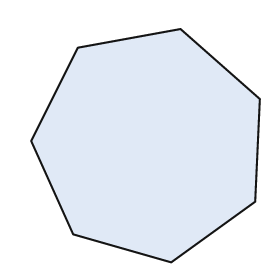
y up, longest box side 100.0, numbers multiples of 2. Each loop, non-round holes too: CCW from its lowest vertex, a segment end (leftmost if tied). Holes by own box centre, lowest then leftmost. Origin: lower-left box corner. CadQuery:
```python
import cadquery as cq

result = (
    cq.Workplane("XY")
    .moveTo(60.0, 0.0)
    .lineTo(96.0, 26.0)
    .lineTo(98.0, 70.0)
    .lineTo(64.0, 100.0)
    .lineTo(20.0, 92.0)
    .lineTo(0.0, 52.0)
    .lineTo(18.0, 12.0)
    .close()
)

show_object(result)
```